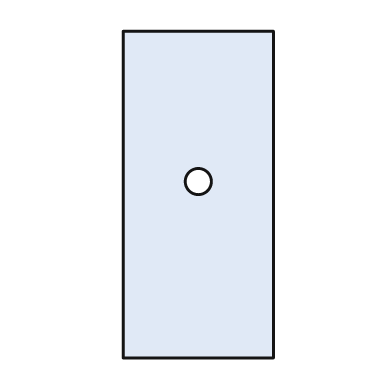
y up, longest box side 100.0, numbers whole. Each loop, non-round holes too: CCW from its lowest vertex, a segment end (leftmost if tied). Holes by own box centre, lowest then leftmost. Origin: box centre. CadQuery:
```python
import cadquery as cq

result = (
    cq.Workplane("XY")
    .moveTo(-23.0, -50.0)
    .lineTo(23.0, -50.0)
    .lineTo(23.0, 50.0)
    .lineTo(-23.0, 50.0)
    .close()
    .moveTo(0.0, 4.0)
    .circle(4.0)
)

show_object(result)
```